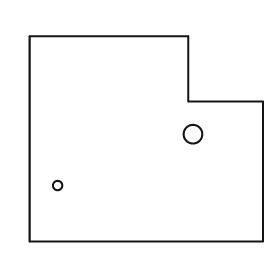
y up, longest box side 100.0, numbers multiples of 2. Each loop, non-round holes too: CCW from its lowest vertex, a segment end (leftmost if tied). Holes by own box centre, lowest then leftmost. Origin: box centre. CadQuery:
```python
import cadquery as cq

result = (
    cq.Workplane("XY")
    .moveTo(-50.0, -44.0)
    .lineTo(50.0, -44.0)
    .lineTo(50.0, 16.0)
    .lineTo(18.0, 16.0)
    .lineTo(18.0, 44.0)
    .lineTo(-50.0, 44.0)
    .close()
    .moveTo(-38.0, -20.0)
    .circle(2.0)
    .moveTo(20.0, 2.0)
    .circle(4.0)
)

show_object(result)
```